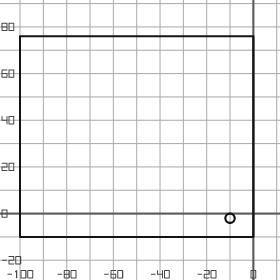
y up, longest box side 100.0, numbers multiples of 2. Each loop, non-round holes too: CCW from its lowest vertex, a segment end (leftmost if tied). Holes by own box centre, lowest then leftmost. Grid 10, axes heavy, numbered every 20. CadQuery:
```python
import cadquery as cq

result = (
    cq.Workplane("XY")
    .moveTo(-100.0, -10.0)
    .lineTo(0.0, -10.0)
    .lineTo(0.0, 76.0)
    .lineTo(-100.0, 76.0)
    .close()
    .moveTo(-10.0, -2.0)
    .circle(2.0)
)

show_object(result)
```